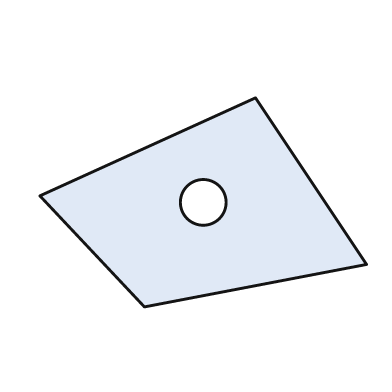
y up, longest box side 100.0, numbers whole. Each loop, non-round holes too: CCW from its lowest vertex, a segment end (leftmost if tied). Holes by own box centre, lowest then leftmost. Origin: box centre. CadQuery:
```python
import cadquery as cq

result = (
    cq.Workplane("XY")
    .moveTo(-18.0, -32.0)
    .lineTo(50.0, -19.0)
    .lineTo(16.0, 32.0)
    .lineTo(-50.0, 2.0)
    .close()
    .moveTo(0.0, 0.0)
    .circle(7.0)
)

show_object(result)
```